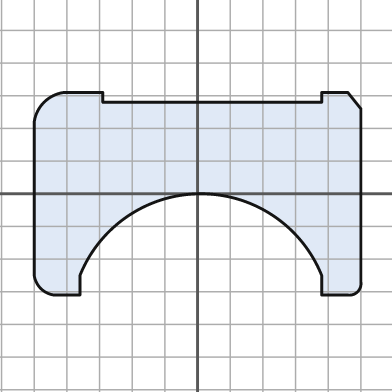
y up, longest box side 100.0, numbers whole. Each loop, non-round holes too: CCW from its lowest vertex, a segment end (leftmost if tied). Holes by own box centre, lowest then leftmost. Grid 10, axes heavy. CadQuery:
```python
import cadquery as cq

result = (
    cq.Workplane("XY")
    .moveTo(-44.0, -31.0)
    .lineTo(-36.0, -31.0)
    .lineTo(-36.0, -25.0)
    .threePointArc((1.0, 0.0), (38.0, -25.0))
    .lineTo(38.0, -31.0)
    .lineTo(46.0, -31.0)
    .threePointArc((49.0, -30.0), (50.0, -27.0))
    .lineTo(50.0, 26.0)
    .lineTo(46.0, 31.0)
    .lineTo(38.0, 31.0)
    .lineTo(38.0, 28.0)
    .lineTo(-29.0, 28.0)
    .lineTo(-29.0, 31.0)
    .lineTo(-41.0, 31.0)
    .threePointArc((-47.0, 28.0), (-50.0, 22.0))
    .lineTo(-50.0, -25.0)
    .threePointArc((-48.0, -29.0), (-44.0, -31.0))
    .close()
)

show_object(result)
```